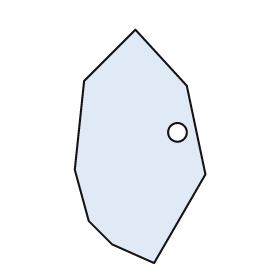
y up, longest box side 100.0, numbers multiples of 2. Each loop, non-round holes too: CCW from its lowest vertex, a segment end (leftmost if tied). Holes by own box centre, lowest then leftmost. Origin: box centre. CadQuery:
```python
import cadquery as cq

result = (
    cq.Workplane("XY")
    .moveTo(6.0, -50.0)
    .lineTo(28.0, -12.0)
    .lineTo(20.0, 26.0)
    .lineTo(-2.0, 50.0)
    .lineTo(-24.0, 28.0)
    .lineTo(-28.0, -10.0)
    .lineTo(-22.0, -32.0)
    .lineTo(-12.0, -42.0)
    .close()
    .moveTo(16.0, 6.0)
    .circle(4.0)
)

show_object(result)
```